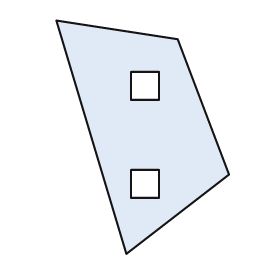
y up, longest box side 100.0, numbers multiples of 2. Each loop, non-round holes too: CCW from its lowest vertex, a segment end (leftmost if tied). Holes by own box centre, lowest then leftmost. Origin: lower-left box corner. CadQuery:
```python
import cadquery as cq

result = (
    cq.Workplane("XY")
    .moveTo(30.0, 0.0)
    .lineTo(74.0, 34.0)
    .lineTo(52.0, 92.0)
    .lineTo(0.0, 100.0)
    .close()
    .moveTo(32.0, 24.0)
    .lineTo(44.0, 24.0)
    .lineTo(44.0, 36.0)
    .lineTo(32.0, 36.0)
    .close()
    .moveTo(32.0, 66.0)
    .lineTo(44.0, 66.0)
    .lineTo(44.0, 78.0)
    .lineTo(32.0, 78.0)
    .close()
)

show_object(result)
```